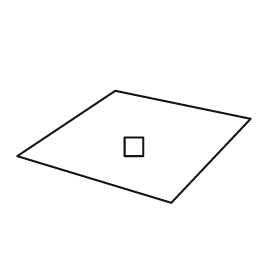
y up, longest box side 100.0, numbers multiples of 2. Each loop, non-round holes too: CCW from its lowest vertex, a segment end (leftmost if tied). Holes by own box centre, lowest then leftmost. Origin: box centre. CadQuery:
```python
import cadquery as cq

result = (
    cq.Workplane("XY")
    .moveTo(16.0, -24.0)
    .lineTo(50.0, 12.0)
    .lineTo(-8.0, 24.0)
    .lineTo(-50.0, -4.0)
    .close()
    .moveTo(-4.0, -4.0)
    .lineTo(4.0, -4.0)
    .lineTo(4.0, 4.0)
    .lineTo(-4.0, 4.0)
    .close()
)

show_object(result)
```